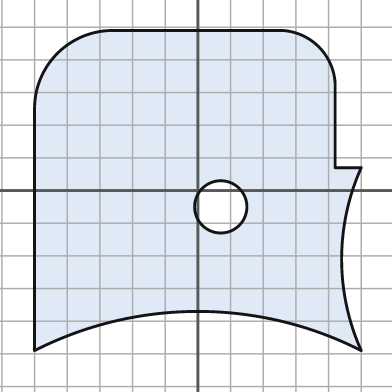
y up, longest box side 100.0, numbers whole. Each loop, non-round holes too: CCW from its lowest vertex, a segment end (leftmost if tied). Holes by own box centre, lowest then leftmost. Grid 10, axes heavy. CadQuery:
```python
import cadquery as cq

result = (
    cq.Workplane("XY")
    .moveTo(-50.0, -49.0)
    .threePointArc((0.0, -37.0), (50.0, -49.0))
    .threePointArc((44.0, -21.0), (50.0, 7.0))
    .lineTo(42.0, 7.0)
    .lineTo(42.0, 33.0)
    .threePointArc((37.0, 44.0), (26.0, 49.0))
    .lineTo(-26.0, 49.0)
    .threePointArc((-43.0, 42.0), (-50.0, 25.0))
    .close()
    .moveTo(7.0, -5.0)
    .circle(8.0)
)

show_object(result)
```